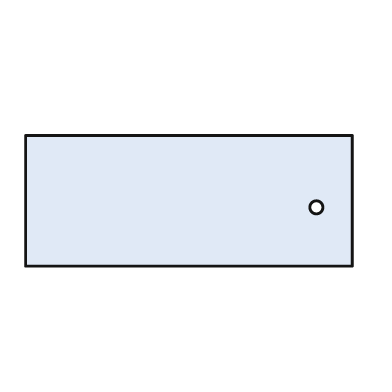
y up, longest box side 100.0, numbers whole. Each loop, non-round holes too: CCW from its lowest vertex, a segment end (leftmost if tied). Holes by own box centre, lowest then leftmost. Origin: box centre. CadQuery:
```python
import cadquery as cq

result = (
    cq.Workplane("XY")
    .moveTo(-50.0, -20.0)
    .lineTo(50.0, -20.0)
    .lineTo(50.0, 20.0)
    .lineTo(-50.0, 20.0)
    .close()
    .moveTo(39.0, -2.0)
    .circle(2.0)
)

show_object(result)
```